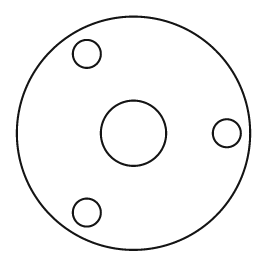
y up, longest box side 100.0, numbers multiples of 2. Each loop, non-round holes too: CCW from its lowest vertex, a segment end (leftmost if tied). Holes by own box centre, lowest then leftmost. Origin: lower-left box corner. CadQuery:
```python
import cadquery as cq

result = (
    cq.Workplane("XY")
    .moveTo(50.0, 50.0)
    .circle(50.0)
    .moveTo(30.0, 16.0)
    .circle(6.0)
    .moveTo(50.0, 50.0)
    .circle(14.0)
    .moveTo(90.0, 50.0)
    .circle(6.0)
    .moveTo(30.0, 84.0)
    .circle(6.0)
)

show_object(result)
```